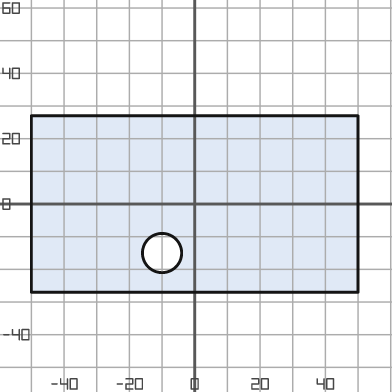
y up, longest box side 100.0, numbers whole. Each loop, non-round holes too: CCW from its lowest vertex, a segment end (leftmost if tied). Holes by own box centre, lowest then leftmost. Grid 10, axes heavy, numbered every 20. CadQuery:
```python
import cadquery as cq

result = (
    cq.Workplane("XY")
    .moveTo(-50.0, -27.0)
    .lineTo(50.0, -27.0)
    .lineTo(50.0, 27.0)
    .lineTo(-50.0, 27.0)
    .close()
    .moveTo(-10.0, -15.0)
    .circle(6.0)
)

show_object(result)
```